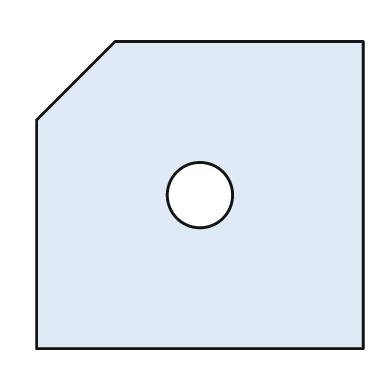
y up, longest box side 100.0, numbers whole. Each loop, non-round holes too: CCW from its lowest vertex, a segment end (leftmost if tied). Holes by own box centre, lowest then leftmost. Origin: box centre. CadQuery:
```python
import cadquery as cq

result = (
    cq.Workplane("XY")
    .moveTo(-50.0, -47.0)
    .lineTo(50.0, -47.0)
    .lineTo(50.0, 47.0)
    .lineTo(-26.0, 47.0)
    .lineTo(-50.0, 23.0)
    .close()
    .moveTo(0.0, 0.0)
    .circle(10.0)
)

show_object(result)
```